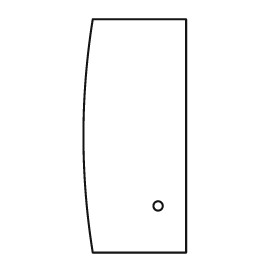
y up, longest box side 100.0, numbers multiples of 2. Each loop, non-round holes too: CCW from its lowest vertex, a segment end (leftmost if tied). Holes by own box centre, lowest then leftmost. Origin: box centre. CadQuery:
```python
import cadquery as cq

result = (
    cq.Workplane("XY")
    .moveTo(-18.0, -50.0)
    .lineTo(22.0, -50.0)
    .lineTo(22.0, 50.0)
    .lineTo(-18.0, 50.0)
    .threePointArc((-22.0, 0.0), (-18.0, -50.0))
    .close()
    .moveTo(10.0, -30.0)
    .circle(2.0)
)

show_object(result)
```